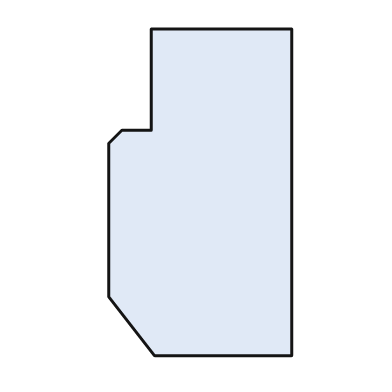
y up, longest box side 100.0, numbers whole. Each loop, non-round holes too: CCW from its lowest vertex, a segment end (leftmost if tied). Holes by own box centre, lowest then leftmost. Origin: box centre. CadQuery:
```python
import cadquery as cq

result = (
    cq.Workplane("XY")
    .moveTo(-14.0, -50.0)
    .lineTo(28.0, -50.0)
    .lineTo(28.0, 50.0)
    .lineTo(-15.0, 50.0)
    .lineTo(-15.0, 19.0)
    .lineTo(-24.0, 19.0)
    .lineTo(-28.0, 15.0)
    .lineTo(-28.0, -32.0)
    .close()
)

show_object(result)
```